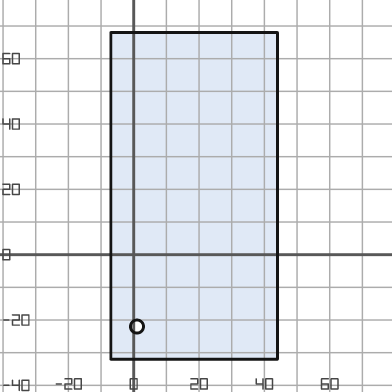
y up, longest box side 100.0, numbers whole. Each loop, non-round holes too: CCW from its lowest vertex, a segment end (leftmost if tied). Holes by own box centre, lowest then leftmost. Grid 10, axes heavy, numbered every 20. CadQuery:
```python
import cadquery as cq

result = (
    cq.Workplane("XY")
    .moveTo(-7.0, -32.0)
    .lineTo(44.0, -32.0)
    .lineTo(44.0, 68.0)
    .lineTo(-7.0, 68.0)
    .close()
    .moveTo(1.0, -22.0)
    .circle(2.0)
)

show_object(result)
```